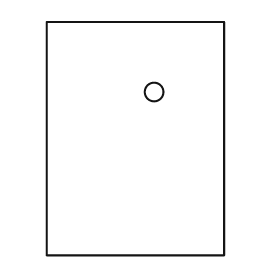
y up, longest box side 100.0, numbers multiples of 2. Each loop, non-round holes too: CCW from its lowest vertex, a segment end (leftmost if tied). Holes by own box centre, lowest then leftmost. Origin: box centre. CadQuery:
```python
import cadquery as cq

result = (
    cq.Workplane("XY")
    .moveTo(-38.0, -50.0)
    .lineTo(38.0, -50.0)
    .lineTo(38.0, 50.0)
    .lineTo(-38.0, 50.0)
    .close()
    .moveTo(8.0, 20.0)
    .circle(4.0)
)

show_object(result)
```